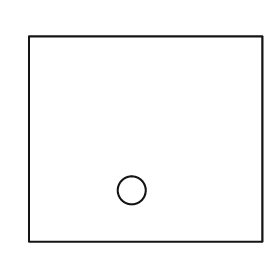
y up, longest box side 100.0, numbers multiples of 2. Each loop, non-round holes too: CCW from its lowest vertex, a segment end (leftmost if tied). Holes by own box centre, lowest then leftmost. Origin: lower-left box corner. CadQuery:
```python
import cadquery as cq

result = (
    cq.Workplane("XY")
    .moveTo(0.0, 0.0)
    .lineTo(100.0, 0.0)
    .lineTo(100.0, 88.0)
    .lineTo(0.0, 88.0)
    .close()
    .moveTo(44.0, 22.0)
    .circle(6.0)
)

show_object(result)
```